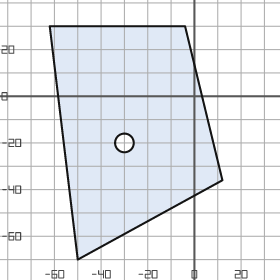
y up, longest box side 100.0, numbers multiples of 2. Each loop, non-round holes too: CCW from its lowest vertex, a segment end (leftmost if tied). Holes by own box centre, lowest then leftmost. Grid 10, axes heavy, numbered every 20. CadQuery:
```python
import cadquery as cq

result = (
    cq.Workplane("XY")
    .moveTo(-50.0, -70.0)
    .lineTo(12.0, -36.0)
    .lineTo(-4.0, 30.0)
    .lineTo(-62.0, 30.0)
    .close()
    .moveTo(-30.0, -20.0)
    .circle(4.0)
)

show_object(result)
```